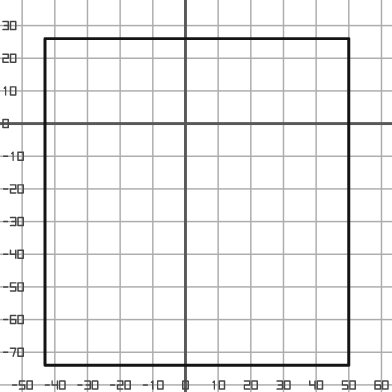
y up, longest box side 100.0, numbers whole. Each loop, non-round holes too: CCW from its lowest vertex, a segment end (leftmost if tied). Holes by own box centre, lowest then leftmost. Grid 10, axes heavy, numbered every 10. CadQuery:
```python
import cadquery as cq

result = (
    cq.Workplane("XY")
    .moveTo(-43.0, -74.0)
    .lineTo(50.0, -74.0)
    .lineTo(50.0, 26.0)
    .lineTo(-43.0, 26.0)
    .close()
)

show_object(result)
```